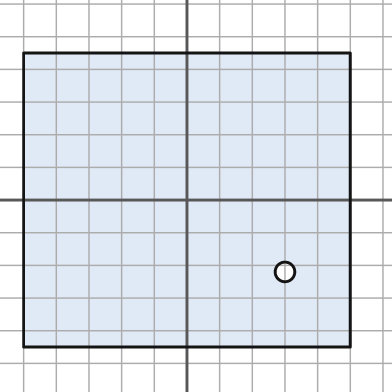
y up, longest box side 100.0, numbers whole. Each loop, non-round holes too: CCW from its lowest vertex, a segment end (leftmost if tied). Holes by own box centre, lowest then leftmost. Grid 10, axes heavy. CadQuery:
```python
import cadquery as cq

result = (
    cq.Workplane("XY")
    .moveTo(-50.0, -45.0)
    .lineTo(50.0, -45.0)
    .lineTo(50.0, 45.0)
    .lineTo(-50.0, 45.0)
    .close()
    .moveTo(30.0, -22.0)
    .circle(3.0)
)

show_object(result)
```